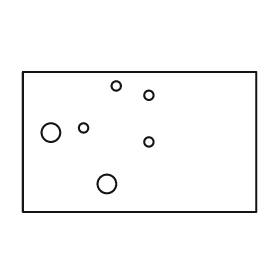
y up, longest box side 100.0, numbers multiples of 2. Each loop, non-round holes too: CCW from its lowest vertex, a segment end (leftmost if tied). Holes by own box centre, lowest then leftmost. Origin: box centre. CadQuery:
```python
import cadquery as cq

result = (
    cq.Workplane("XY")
    .moveTo(-50.0, -30.0)
    .lineTo(50.0, -30.0)
    .lineTo(50.0, 30.0)
    .lineTo(-50.0, 30.0)
    .close()
    .moveTo(-14.0, -18.0)
    .circle(4.0)
    .moveTo(4.0, 0.0)
    .circle(2.0)
    .moveTo(-38.0, 4.0)
    .circle(4.0)
    .moveTo(-24.0, 6.0)
    .circle(2.0)
    .moveTo(4.0, 20.0)
    .circle(2.0)
    .moveTo(-10.0, 24.0)
    .circle(2.0)
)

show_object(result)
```